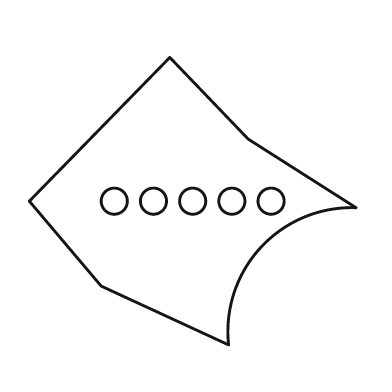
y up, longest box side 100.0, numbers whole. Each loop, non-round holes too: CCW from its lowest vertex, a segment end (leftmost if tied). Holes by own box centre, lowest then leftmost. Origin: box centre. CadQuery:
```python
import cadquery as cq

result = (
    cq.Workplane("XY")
    .moveTo(11.0, -44.0)
    .threePointArc((21.0, -14.0), (50.0, -2.0))
    .lineTo(17.0, 19.0)
    .lineTo(-7.0, 44.0)
    .lineTo(-50.0, 0.0)
    .lineTo(-28.0, -26.0)
    .close()
    .moveTo(-24.0, 0.0)
    .circle(4.0)
    .moveTo(-12.0, 0.0)
    .circle(4.0)
    .moveTo(0.0, 0.0)
    .circle(4.0)
    .moveTo(12.0, 0.0)
    .circle(4.0)
    .moveTo(24.0, 0.0)
    .circle(4.0)
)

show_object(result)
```